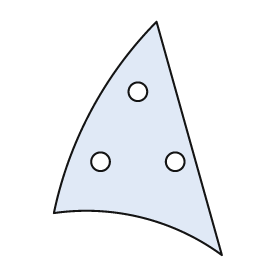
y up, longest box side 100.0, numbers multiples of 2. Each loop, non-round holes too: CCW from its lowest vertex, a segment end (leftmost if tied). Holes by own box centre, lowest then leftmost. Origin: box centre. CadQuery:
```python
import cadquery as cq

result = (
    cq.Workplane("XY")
    .moveTo(36.0, -50.0)
    .lineTo(8.0, 50.0)
    .threePointArc((-20.0, 12.0), (-36.0, -32.0))
    .threePointArc((2.0, -34.0), (36.0, -50.0))
    .close()
    .moveTo(-16.0, -10.0)
    .circle(4.0)
    .moveTo(16.0, -10.0)
    .circle(4.0)
    .moveTo(0.0, 20.0)
    .circle(4.0)
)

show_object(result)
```